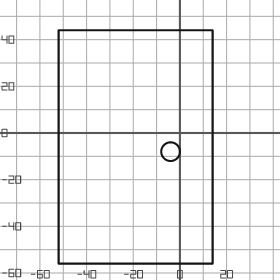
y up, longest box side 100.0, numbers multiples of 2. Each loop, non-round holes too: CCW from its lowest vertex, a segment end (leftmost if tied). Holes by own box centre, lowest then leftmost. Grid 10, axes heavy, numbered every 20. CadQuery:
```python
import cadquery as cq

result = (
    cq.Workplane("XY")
    .moveTo(-52.0, -56.0)
    .lineTo(14.0, -56.0)
    .lineTo(14.0, 44.0)
    .lineTo(-52.0, 44.0)
    .close()
    .moveTo(-4.0, -8.0)
    .circle(4.0)
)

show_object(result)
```